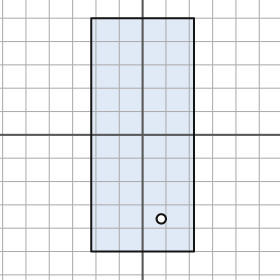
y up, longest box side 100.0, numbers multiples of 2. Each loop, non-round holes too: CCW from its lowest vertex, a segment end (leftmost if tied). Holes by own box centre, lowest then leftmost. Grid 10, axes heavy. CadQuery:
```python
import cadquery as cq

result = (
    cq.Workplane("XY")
    .moveTo(-22.0, -50.0)
    .lineTo(22.0, -50.0)
    .lineTo(22.0, 50.0)
    .lineTo(-22.0, 50.0)
    .close()
    .moveTo(8.0, -36.0)
    .circle(2.0)
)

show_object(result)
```